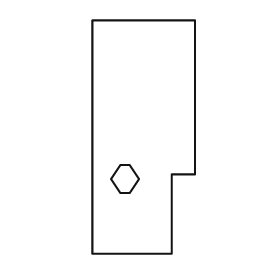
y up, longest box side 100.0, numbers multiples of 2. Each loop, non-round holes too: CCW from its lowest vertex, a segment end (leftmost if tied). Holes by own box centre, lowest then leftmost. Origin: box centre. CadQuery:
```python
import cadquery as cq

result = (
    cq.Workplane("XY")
    .moveTo(-22.0, -50.0)
    .lineTo(12.0, -50.0)
    .lineTo(12.0, -16.0)
    .lineTo(22.0, -16.0)
    .lineTo(22.0, 50.0)
    .lineTo(-22.0, 50.0)
    .close()
    .moveTo(-10.0, -24.0)
    .lineTo(-6.0, -24.0)
    .lineTo(-2.0, -18.0)
    .lineTo(-6.0, -12.0)
    .lineTo(-10.0, -12.0)
    .lineTo(-14.0, -18.0)
    .close()
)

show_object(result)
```